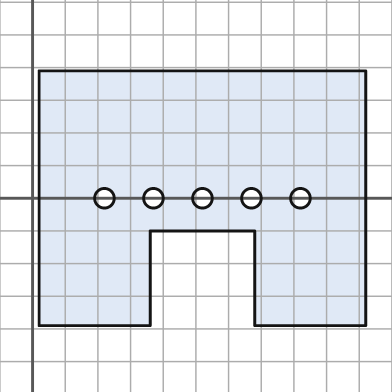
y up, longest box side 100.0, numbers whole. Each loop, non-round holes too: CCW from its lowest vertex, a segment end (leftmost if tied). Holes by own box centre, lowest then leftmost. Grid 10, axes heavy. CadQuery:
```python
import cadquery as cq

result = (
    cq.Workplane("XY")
    .moveTo(2.0, -39.0)
    .lineTo(36.0, -39.0)
    .lineTo(36.0, -10.0)
    .lineTo(68.0, -10.0)
    .lineTo(68.0, -39.0)
    .lineTo(102.0, -39.0)
    .lineTo(102.0, 39.0)
    .lineTo(2.0, 39.0)
    .close()
    .moveTo(22.0, 0.0)
    .circle(3.0)
    .moveTo(37.0, 0.0)
    .circle(3.0)
    .moveTo(52.0, 0.0)
    .circle(3.0)
    .moveTo(67.0, 0.0)
    .circle(3.0)
    .moveTo(82.0, 0.0)
    .circle(3.0)
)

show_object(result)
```